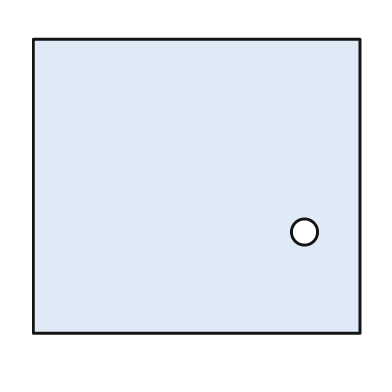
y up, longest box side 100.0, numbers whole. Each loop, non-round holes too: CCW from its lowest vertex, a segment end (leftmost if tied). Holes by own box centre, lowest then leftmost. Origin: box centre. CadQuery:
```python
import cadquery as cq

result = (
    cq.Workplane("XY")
    .moveTo(-50.0, -45.0)
    .lineTo(50.0, -45.0)
    .lineTo(50.0, 45.0)
    .lineTo(-50.0, 45.0)
    .close()
    .moveTo(33.0, -14.0)
    .circle(4.0)
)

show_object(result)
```